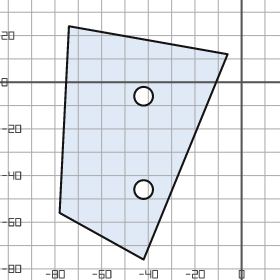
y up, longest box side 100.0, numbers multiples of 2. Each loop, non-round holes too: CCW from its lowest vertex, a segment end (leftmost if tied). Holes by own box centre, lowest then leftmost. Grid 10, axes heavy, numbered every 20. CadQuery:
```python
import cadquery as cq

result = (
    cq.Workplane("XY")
    .moveTo(-42.0, -76.0)
    .lineTo(-6.0, 12.0)
    .lineTo(-74.0, 24.0)
    .lineTo(-78.0, -56.0)
    .close()
    .moveTo(-42.0, -46.0)
    .circle(4.0)
    .moveTo(-42.0, -6.0)
    .circle(4.0)
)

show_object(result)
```